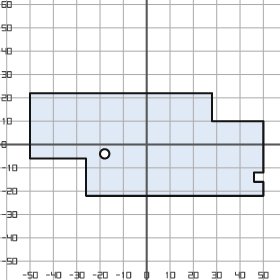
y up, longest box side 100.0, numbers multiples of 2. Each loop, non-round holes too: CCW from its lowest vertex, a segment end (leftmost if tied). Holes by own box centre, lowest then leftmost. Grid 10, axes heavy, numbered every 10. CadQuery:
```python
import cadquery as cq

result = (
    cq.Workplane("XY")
    .moveTo(-26.0, -22.0)
    .lineTo(50.0, -22.0)
    .lineTo(50.0, -16.0)
    .lineTo(46.0, -16.0)
    .lineTo(46.0, -12.0)
    .lineTo(50.0, -12.0)
    .lineTo(50.0, 10.0)
    .lineTo(28.0, 10.0)
    .lineTo(28.0, 22.0)
    .lineTo(-50.0, 22.0)
    .lineTo(-50.0, -6.0)
    .lineTo(-26.0, -6.0)
    .close()
    .moveTo(-18.0, -4.0)
    .circle(2.0)
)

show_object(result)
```